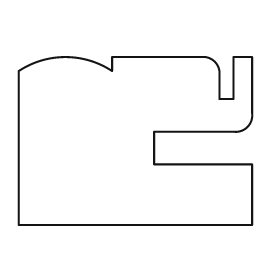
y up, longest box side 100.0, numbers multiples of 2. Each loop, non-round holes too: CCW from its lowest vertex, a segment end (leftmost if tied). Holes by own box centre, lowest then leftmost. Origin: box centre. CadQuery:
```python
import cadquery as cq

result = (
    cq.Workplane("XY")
    .moveTo(-50.0, -36.0)
    .lineTo(50.0, -36.0)
    .lineTo(50.0, -10.0)
    .lineTo(8.0, -10.0)
    .lineTo(8.0, 4.0)
    .lineTo(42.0, 4.0)
    .threePointArc((48.0, 6.0), (50.0, 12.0))
    .lineTo(50.0, 36.0)
    .lineTo(42.0, 36.0)
    .lineTo(42.0, 18.0)
    .lineTo(36.0, 18.0)
    .lineTo(36.0, 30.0)
    .threePointArc((34.0, 34.0), (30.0, 36.0))
    .lineTo(-10.0, 36.0)
    .lineTo(-10.0, 30.0)
    .threePointArc((-30.0, 36.0), (-50.0, 30.0))
    .close()
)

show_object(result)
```